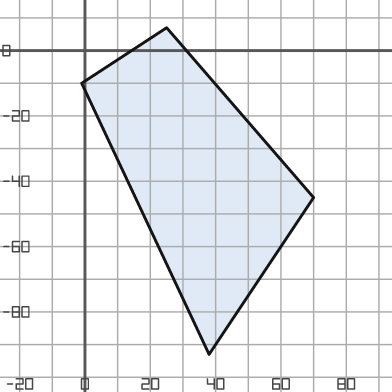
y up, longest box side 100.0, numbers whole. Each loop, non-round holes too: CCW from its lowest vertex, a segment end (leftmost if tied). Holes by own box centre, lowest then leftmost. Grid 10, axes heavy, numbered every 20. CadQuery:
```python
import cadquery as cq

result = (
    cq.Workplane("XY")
    .moveTo(38.0, -93.0)
    .lineTo(70.0, -45.0)
    .lineTo(25.0, 7.0)
    .lineTo(-1.0, -10.0)
    .close()
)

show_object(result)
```